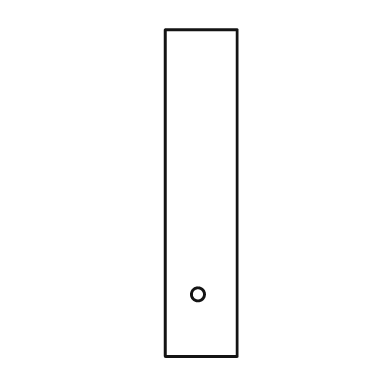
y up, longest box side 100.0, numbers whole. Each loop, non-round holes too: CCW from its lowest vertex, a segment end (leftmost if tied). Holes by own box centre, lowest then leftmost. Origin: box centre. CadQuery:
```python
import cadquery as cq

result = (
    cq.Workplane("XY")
    .moveTo(-11.0, -50.0)
    .lineTo(11.0, -50.0)
    .lineTo(11.0, 50.0)
    .lineTo(-11.0, 50.0)
    .close()
    .moveTo(-1.0, -31.0)
    .circle(2.0)
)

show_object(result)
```